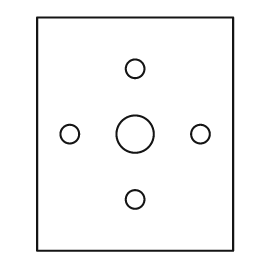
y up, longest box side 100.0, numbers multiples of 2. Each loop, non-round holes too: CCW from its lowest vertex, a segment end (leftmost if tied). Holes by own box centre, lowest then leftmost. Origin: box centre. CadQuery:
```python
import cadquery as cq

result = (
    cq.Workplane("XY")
    .moveTo(-42.0, -50.0)
    .lineTo(42.0, -50.0)
    .lineTo(42.0, 50.0)
    .lineTo(-42.0, 50.0)
    .close()
    .moveTo(0.0, -28.0)
    .circle(4.0)
    .moveTo(-28.0, 0.0)
    .circle(4.0)
    .moveTo(0.0, 0.0)
    .circle(8.0)
    .moveTo(28.0, 0.0)
    .circle(4.0)
    .moveTo(0.0, 28.0)
    .circle(4.0)
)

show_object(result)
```